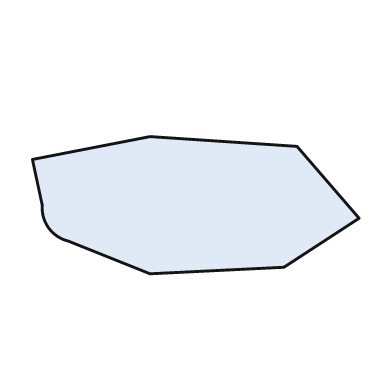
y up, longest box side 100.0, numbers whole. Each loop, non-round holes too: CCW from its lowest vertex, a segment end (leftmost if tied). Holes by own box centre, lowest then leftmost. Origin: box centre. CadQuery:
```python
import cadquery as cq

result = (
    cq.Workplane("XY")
    .moveTo(-14.0, -21.0)
    .lineTo(27.0, -19.0)
    .lineTo(50.0, -4.0)
    .lineTo(31.0, 18.0)
    .lineTo(-14.0, 21.0)
    .lineTo(-50.0, 14.0)
    .lineTo(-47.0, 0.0)
    .threePointArc((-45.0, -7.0), (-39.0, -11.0))
    .close()
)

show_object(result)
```